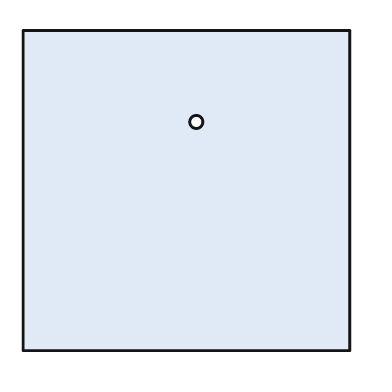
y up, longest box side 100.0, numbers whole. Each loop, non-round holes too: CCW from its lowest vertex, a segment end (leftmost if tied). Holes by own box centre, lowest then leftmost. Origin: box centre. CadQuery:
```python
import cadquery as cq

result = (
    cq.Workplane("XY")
    .moveTo(-50.0, -49.0)
    .lineTo(50.0, -49.0)
    .lineTo(50.0, 49.0)
    .lineTo(-50.0, 49.0)
    .close()
    .moveTo(3.0, 21.0)
    .circle(2.0)
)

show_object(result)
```